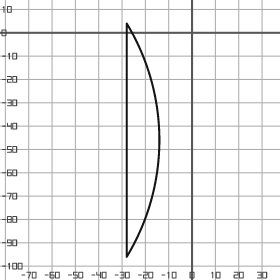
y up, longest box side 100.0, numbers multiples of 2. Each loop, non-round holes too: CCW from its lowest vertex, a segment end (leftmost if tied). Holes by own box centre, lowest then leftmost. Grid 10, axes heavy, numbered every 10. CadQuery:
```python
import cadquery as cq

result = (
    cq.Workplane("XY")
    .moveTo(-28.0, -96.0)
    .threePointArc((-14.0, -46.0), (-28.0, 4.0))
    .close()
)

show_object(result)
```